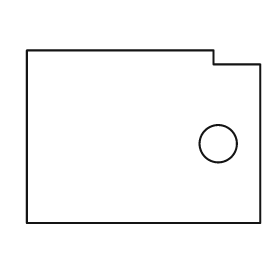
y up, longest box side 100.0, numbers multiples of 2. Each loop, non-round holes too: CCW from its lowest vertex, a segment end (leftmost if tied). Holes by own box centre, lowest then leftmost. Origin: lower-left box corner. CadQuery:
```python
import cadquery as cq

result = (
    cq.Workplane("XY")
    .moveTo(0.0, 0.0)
    .lineTo(100.0, 0.0)
    .lineTo(100.0, 68.0)
    .lineTo(80.0, 68.0)
    .lineTo(80.0, 74.0)
    .lineTo(0.0, 74.0)
    .close()
    .moveTo(82.0, 34.0)
    .circle(8.0)
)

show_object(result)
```